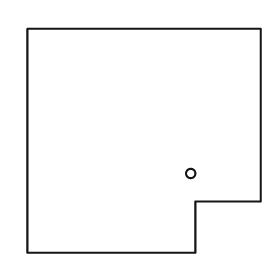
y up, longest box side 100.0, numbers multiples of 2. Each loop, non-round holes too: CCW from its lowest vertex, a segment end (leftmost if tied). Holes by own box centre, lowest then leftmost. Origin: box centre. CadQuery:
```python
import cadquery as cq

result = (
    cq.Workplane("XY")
    .moveTo(-50.0, -48.0)
    .lineTo(22.0, -48.0)
    .lineTo(22.0, -26.0)
    .lineTo(50.0, -26.0)
    .lineTo(50.0, 48.0)
    .lineTo(-50.0, 48.0)
    .close()
    .moveTo(20.0, -14.0)
    .circle(2.0)
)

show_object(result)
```